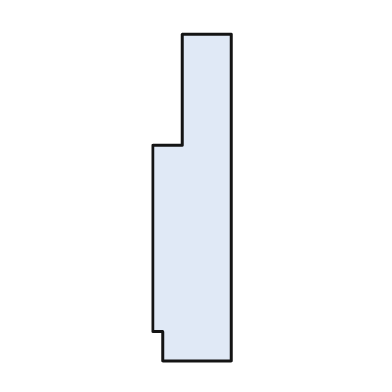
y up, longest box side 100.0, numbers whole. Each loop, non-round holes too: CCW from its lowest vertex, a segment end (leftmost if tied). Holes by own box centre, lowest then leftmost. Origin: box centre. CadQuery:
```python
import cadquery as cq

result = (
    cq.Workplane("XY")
    .moveTo(-9.0, -50.0)
    .lineTo(12.0, -50.0)
    .lineTo(12.0, 50.0)
    .lineTo(-3.0, 50.0)
    .lineTo(-3.0, 16.0)
    .lineTo(-12.0, 16.0)
    .lineTo(-12.0, -41.0)
    .lineTo(-9.0, -41.0)
    .close()
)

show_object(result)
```